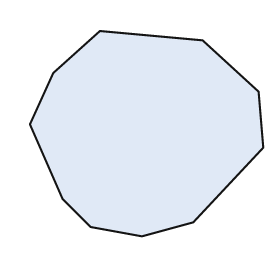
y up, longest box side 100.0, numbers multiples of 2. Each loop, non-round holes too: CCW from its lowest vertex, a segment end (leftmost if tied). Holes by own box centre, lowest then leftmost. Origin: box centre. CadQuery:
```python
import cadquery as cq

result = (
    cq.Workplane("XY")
    .moveTo(-2.0, -44.0)
    .lineTo(20.0, -38.0)
    .lineTo(50.0, -6.0)
    .lineTo(48.0, 18.0)
    .lineTo(24.0, 40.0)
    .lineTo(-20.0, 44.0)
    .lineTo(-40.0, 26.0)
    .lineTo(-50.0, 4.0)
    .lineTo(-36.0, -28.0)
    .lineTo(-24.0, -40.0)
    .close()
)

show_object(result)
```